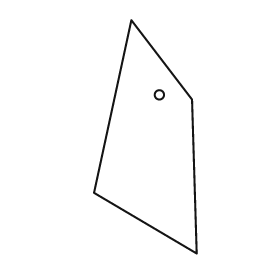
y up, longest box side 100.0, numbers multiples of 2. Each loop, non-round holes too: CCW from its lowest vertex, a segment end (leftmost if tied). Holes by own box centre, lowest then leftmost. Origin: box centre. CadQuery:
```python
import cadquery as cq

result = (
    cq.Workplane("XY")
    .moveTo(22.0, -50.0)
    .lineTo(20.0, 16.0)
    .lineTo(-6.0, 50.0)
    .lineTo(-22.0, -24.0)
    .close()
    .moveTo(6.0, 18.0)
    .circle(2.0)
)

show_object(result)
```